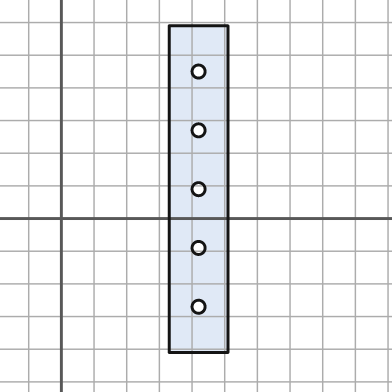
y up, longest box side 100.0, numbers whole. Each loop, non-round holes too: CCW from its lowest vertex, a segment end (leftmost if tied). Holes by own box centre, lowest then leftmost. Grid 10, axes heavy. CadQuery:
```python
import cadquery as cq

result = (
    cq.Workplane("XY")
    .moveTo(33.0, -41.0)
    .lineTo(51.0, -41.0)
    .lineTo(51.0, 59.0)
    .lineTo(33.0, 59.0)
    .close()
    .moveTo(42.0, -27.0)
    .circle(2.0)
    .moveTo(42.0, -9.0)
    .circle(2.0)
    .moveTo(42.0, 9.0)
    .circle(2.0)
    .moveTo(42.0, 27.0)
    .circle(2.0)
    .moveTo(42.0, 45.0)
    .circle(2.0)
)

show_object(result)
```